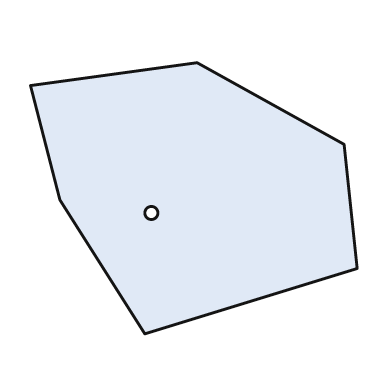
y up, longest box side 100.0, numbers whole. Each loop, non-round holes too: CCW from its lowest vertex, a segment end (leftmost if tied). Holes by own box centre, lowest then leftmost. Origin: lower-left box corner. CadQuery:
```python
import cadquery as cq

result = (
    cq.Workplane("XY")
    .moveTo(35.0, 0.0)
    .lineTo(100.0, 20.0)
    .lineTo(96.0, 58.0)
    .lineTo(51.0, 83.0)
    .lineTo(0.0, 76.0)
    .lineTo(9.0, 41.0)
    .close()
    .moveTo(37.0, 37.0)
    .circle(2.0)
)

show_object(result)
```